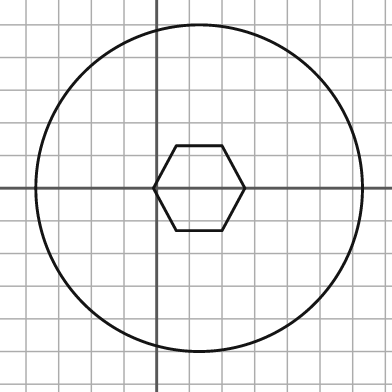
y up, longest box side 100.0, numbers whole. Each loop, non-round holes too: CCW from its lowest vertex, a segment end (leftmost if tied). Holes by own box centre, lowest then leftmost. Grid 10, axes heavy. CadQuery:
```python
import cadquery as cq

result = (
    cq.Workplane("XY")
    .moveTo(13.0, 0.0)
    .circle(50.0)
    .moveTo(6.0, -13.0)
    .lineTo(20.0, -13.0)
    .lineTo(27.0, 0.0)
    .lineTo(20.0, 13.0)
    .lineTo(6.0, 13.0)
    .lineTo(-1.0, 0.0)
    .close()
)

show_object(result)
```